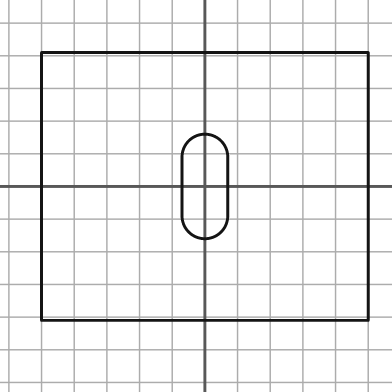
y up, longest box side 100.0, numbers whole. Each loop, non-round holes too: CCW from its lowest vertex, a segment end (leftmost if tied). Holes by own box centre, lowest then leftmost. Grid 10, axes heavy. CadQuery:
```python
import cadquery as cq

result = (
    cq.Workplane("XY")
    .moveTo(-50.0, -41.0)
    .lineTo(50.0, -41.0)
    .lineTo(50.0, 41.0)
    .lineTo(-50.0, 41.0)
    .close()
    .moveTo(-7.0, -9.0)
    .threePointArc((0.0, -16.0), (7.0, -9.0))
    .lineTo(7.0, 9.0)
    .threePointArc((0.0, 16.0), (-7.0, 9.0))
    .close()
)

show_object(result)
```